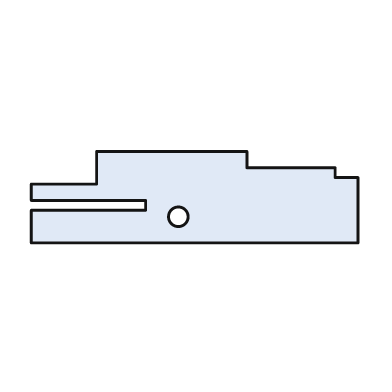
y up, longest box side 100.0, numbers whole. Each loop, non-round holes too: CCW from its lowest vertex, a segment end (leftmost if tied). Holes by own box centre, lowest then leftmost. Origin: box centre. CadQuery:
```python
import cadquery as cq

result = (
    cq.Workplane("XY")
    .moveTo(-50.0, -14.0)
    .lineTo(50.0, -14.0)
    .lineTo(50.0, 6.0)
    .lineTo(43.0, 6.0)
    .lineTo(43.0, 9.0)
    .lineTo(16.0, 9.0)
    .lineTo(16.0, 14.0)
    .lineTo(-30.0, 14.0)
    .lineTo(-30.0, 4.0)
    .lineTo(-50.0, 4.0)
    .lineTo(-50.0, -1.0)
    .lineTo(-15.0, -1.0)
    .lineTo(-15.0, -4.0)
    .lineTo(-50.0, -4.0)
    .close()
    .moveTo(-5.0, -6.0)
    .circle(3.0)
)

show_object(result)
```